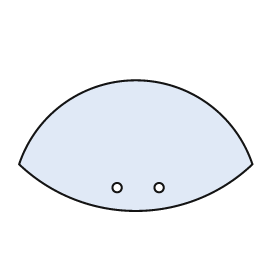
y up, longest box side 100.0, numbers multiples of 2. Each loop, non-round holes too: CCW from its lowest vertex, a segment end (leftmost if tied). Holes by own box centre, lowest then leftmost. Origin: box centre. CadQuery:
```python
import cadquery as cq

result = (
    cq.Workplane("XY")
    .moveTo(-50.0, -8.0)
    .threePointArc((0.0, -28.0), (50.0, -8.0))
    .threePointArc((0.0, 28.0), (-50.0, -8.0))
    .close()
    .moveTo(-8.0, -18.0)
    .circle(2.0)
    .moveTo(10.0, -18.0)
    .circle(2.0)
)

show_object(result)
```